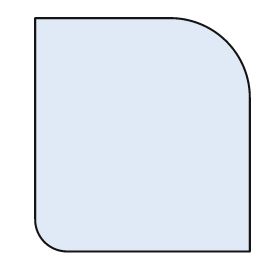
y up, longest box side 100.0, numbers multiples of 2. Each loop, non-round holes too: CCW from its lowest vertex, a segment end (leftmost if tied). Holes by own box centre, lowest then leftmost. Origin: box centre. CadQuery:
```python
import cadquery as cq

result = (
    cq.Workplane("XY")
    .moveTo(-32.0, -50.0)
    .lineTo(46.0, -50.0)
    .lineTo(46.0, 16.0)
    .threePointArc((36.0, 40.0), (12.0, 50.0))
    .lineTo(-46.0, 50.0)
    .lineTo(-46.0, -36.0)
    .threePointArc((-42.0, -46.0), (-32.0, -50.0))
    .close()
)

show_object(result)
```